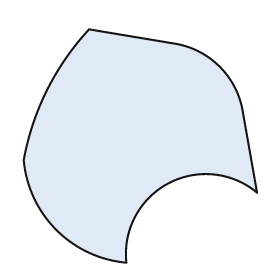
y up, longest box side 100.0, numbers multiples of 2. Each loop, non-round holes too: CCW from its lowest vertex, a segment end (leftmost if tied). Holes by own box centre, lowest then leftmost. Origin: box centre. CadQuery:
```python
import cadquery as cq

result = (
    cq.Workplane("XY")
    .moveTo(-6.0, -50.0)
    .threePointArc((12.0, -16.0), (50.0, -20.0))
    .lineTo(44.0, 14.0)
    .threePointArc((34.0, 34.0), (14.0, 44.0))
    .lineTo(-22.0, 50.0)
    .threePointArc((-40.0, 24.0), (-50.0, -6.0))
    .threePointArc((-36.0, -36.0), (-6.0, -50.0))
    .close()
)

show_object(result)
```